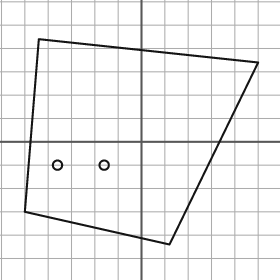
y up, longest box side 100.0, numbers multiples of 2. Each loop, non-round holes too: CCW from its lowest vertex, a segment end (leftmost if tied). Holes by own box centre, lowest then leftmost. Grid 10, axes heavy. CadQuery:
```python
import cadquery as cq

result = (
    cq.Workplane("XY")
    .moveTo(12.0, -44.0)
    .lineTo(50.0, 34.0)
    .lineTo(-44.0, 44.0)
    .lineTo(-50.0, -30.0)
    .close()
    .moveTo(-36.0, -10.0)
    .circle(2.0)
    .moveTo(-16.0, -10.0)
    .circle(2.0)
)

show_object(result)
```